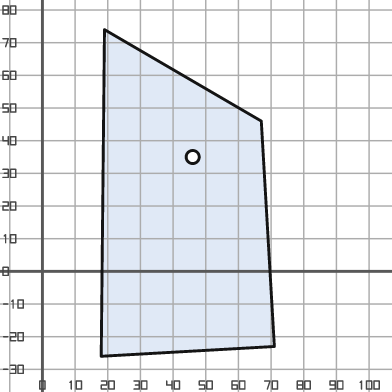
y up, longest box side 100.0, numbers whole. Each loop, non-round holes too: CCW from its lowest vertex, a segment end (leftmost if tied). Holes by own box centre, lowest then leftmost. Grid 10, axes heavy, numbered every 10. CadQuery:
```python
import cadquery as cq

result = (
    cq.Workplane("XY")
    .moveTo(18.0, -26.0)
    .lineTo(71.0, -23.0)
    .lineTo(67.0, 46.0)
    .lineTo(19.0, 74.0)
    .close()
    .moveTo(46.0, 35.0)
    .circle(2.0)
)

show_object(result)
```